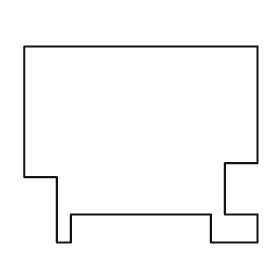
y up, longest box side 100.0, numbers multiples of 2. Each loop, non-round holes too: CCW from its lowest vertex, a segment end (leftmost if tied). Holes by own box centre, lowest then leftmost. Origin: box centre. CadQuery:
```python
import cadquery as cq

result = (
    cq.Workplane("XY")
    .moveTo(-36.0, -42.0)
    .lineTo(-30.0, -42.0)
    .lineTo(-30.0, -30.0)
    .lineTo(30.0, -30.0)
    .lineTo(30.0, -42.0)
    .lineTo(50.0, -42.0)
    .lineTo(50.0, -30.0)
    .lineTo(36.0, -30.0)
    .lineTo(36.0, -8.0)
    .lineTo(50.0, -8.0)
    .lineTo(50.0, 42.0)
    .lineTo(-50.0, 42.0)
    .lineTo(-50.0, -14.0)
    .lineTo(-36.0, -14.0)
    .close()
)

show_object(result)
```